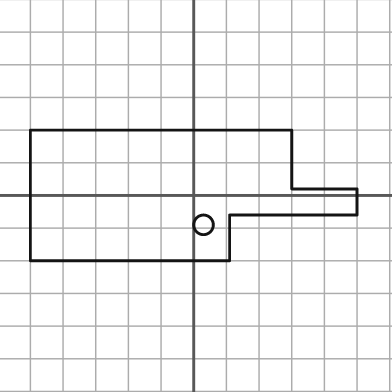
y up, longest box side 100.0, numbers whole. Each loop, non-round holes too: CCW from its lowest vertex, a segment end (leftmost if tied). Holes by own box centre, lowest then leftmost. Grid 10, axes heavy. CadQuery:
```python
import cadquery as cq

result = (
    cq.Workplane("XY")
    .moveTo(-50.0, -20.0)
    .lineTo(11.0, -20.0)
    .lineTo(11.0, -6.0)
    .lineTo(50.0, -6.0)
    .lineTo(50.0, 2.0)
    .lineTo(30.0, 2.0)
    .lineTo(30.0, 20.0)
    .lineTo(-50.0, 20.0)
    .close()
    .moveTo(3.0, -9.0)
    .circle(3.0)
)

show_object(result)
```